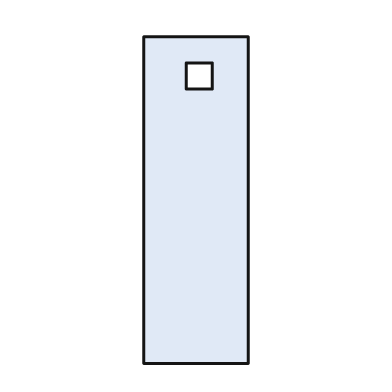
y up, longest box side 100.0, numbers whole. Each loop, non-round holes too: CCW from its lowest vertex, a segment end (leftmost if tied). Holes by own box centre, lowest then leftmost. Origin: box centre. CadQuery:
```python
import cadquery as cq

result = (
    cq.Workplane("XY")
    .moveTo(-16.0, -50.0)
    .lineTo(16.0, -50.0)
    .lineTo(16.0, 50.0)
    .lineTo(-16.0, 50.0)
    .close()
    .moveTo(-3.0, 34.0)
    .lineTo(5.0, 34.0)
    .lineTo(5.0, 42.0)
    .lineTo(-3.0, 42.0)
    .close()
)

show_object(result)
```